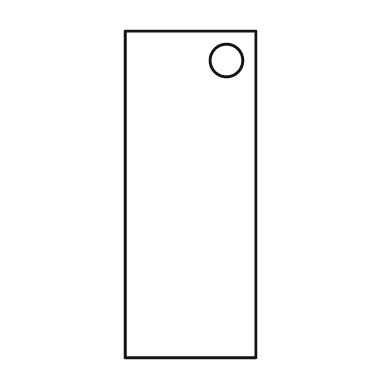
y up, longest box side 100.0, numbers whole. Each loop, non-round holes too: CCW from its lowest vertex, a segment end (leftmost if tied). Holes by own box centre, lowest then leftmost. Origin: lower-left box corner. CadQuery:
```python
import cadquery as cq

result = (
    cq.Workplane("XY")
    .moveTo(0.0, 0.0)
    .lineTo(40.0, 0.0)
    .lineTo(40.0, 100.0)
    .lineTo(0.0, 100.0)
    .close()
    .moveTo(31.0, 91.0)
    .circle(5.0)
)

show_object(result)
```